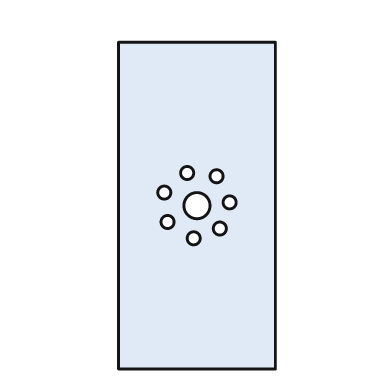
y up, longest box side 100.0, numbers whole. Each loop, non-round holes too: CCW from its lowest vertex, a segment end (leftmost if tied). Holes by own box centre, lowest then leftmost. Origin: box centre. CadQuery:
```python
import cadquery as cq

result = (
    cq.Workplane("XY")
    .moveTo(-24.0, -50.0)
    .lineTo(24.0, -50.0)
    .lineTo(24.0, 50.0)
    .lineTo(-24.0, 50.0)
    .close()
    .moveTo(-1.0, -10.0)
    .circle(2.0)
    .moveTo(7.0, -7.0)
    .circle(2.0)
    .moveTo(-9.0, -5.0)
    .circle(2.0)
    .moveTo(0.0, 0.0)
    .circle(4.0)
    .moveTo(10.0, 1.0)
    .circle(2.0)
    .moveTo(-10.0, 4.0)
    .circle(2.0)
    .moveTo(6.0, 9.0)
    .circle(2.0)
    .moveTo(-3.0, 10.0)
    .circle(2.0)
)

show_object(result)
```